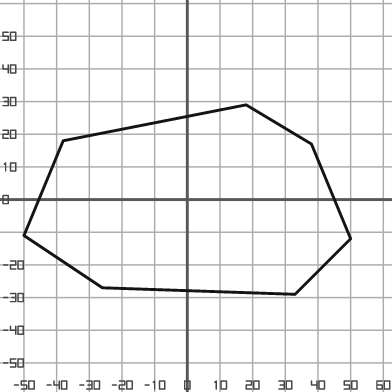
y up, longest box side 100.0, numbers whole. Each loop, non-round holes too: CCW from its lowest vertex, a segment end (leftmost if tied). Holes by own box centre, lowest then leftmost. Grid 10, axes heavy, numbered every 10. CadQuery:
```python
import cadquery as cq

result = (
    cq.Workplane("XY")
    .moveTo(33.0, -29.0)
    .lineTo(50.0, -12.0)
    .lineTo(38.0, 17.0)
    .lineTo(18.0, 29.0)
    .lineTo(-38.0, 18.0)
    .lineTo(-50.0, -11.0)
    .lineTo(-26.0, -27.0)
    .close()
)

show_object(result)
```